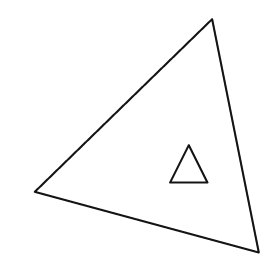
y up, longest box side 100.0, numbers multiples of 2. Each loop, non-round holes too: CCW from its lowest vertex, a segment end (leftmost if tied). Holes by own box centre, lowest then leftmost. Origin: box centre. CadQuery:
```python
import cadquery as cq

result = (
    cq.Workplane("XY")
    .moveTo(48.0, -50.0)
    .lineTo(28.0, 50.0)
    .lineTo(-48.0, -24.0)
    .close()
    .moveTo(10.0, -20.0)
    .lineTo(26.0, -20.0)
    .lineTo(18.0, -4.0)
    .close()
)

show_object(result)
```